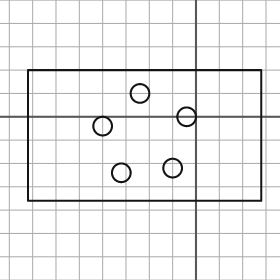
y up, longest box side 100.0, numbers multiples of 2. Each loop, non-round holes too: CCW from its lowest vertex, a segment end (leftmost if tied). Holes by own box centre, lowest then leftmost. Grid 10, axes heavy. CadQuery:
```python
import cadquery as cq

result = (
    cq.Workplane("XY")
    .moveTo(-72.0, -36.0)
    .lineTo(28.0, -36.0)
    .lineTo(28.0, 20.0)
    .lineTo(-72.0, 20.0)
    .close()
    .moveTo(-32.0, -24.0)
    .circle(4.0)
    .moveTo(-10.0, -22.0)
    .circle(4.0)
    .moveTo(-40.0, -4.0)
    .circle(4.0)
    .moveTo(-4.0, 0.0)
    .circle(4.0)
    .moveTo(-24.0, 10.0)
    .circle(4.0)
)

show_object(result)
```